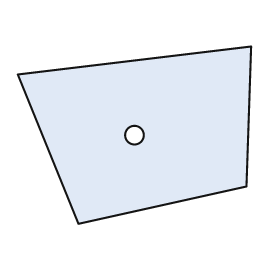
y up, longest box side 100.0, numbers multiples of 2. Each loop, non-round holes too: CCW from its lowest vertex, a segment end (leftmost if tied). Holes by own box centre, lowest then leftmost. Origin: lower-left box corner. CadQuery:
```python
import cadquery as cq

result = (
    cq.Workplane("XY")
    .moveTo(26.0, 0.0)
    .lineTo(98.0, 16.0)
    .lineTo(100.0, 76.0)
    .lineTo(0.0, 64.0)
    .close()
    .moveTo(50.0, 38.0)
    .circle(4.0)
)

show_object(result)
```